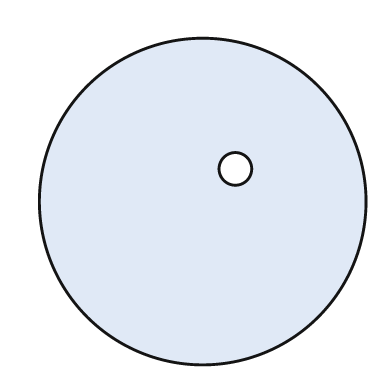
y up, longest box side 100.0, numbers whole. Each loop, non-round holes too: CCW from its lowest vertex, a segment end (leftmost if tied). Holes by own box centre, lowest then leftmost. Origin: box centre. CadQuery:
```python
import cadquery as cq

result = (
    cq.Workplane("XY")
    .moveTo(0.0, 0.0)
    .circle(50.0)
    .moveTo(10.0, 10.0)
    .circle(5.0)
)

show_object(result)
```